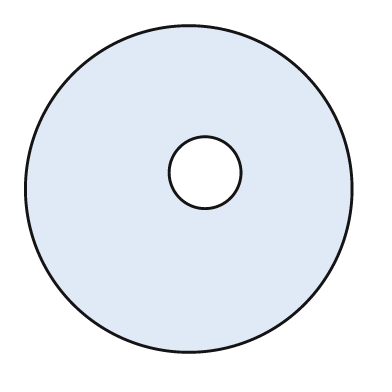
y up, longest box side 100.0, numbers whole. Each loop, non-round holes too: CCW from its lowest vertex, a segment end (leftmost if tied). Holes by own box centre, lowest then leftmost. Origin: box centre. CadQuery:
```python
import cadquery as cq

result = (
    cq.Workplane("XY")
    .moveTo(0.0, 0.0)
    .circle(50.0)
    .moveTo(5.0, 5.0)
    .circle(11.0)
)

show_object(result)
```